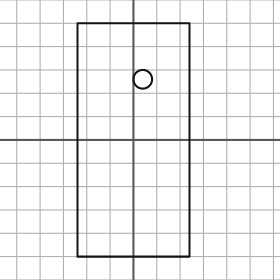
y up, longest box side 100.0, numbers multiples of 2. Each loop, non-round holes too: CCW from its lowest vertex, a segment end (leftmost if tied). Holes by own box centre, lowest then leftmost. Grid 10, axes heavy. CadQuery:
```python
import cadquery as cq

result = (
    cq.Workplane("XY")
    .moveTo(-24.0, -50.0)
    .lineTo(24.0, -50.0)
    .lineTo(24.0, 50.0)
    .lineTo(-24.0, 50.0)
    .close()
    .moveTo(4.0, 26.0)
    .circle(4.0)
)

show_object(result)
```